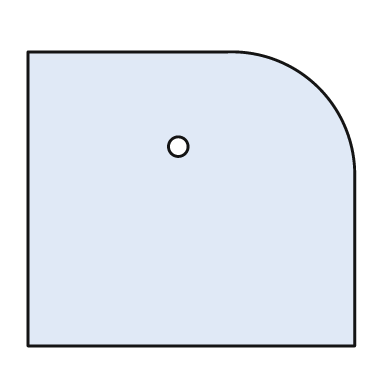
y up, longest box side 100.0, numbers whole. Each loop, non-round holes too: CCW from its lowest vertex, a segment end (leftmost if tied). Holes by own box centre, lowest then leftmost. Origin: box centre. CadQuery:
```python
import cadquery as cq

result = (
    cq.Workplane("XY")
    .moveTo(-50.0, -45.0)
    .lineTo(50.0, -45.0)
    .lineTo(50.0, 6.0)
    .threePointArc((39.0, 34.0), (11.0, 45.0))
    .lineTo(-50.0, 45.0)
    .close()
    .moveTo(-4.0, 16.0)
    .circle(3.0)
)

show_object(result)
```